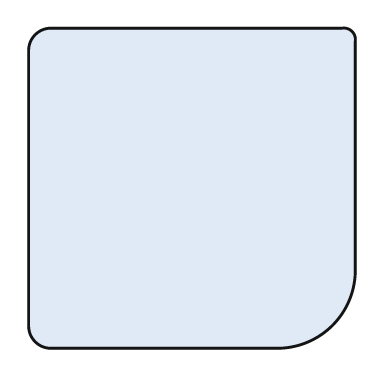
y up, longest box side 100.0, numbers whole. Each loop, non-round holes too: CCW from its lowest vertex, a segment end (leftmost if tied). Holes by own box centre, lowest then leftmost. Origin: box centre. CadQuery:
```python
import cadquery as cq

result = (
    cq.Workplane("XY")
    .moveTo(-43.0, -49.0)
    .lineTo(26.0, -49.0)
    .threePointArc((43.0, -42.0), (50.0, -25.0))
    .lineTo(50.0, 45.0)
    .threePointArc((49.0, 48.0), (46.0, 49.0))
    .lineTo(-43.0, 49.0)
    .threePointArc((-48.0, 47.0), (-50.0, 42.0))
    .lineTo(-50.0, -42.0)
    .threePointArc((-48.0, -47.0), (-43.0, -49.0))
    .close()
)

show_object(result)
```